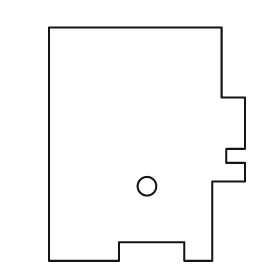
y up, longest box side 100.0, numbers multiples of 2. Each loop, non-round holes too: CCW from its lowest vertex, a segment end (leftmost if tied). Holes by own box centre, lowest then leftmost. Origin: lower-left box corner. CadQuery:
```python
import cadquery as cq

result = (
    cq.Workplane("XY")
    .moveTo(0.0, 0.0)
    .lineTo(30.0, 0.0)
    .lineTo(30.0, 8.0)
    .lineTo(58.0, 8.0)
    .lineTo(58.0, 0.0)
    .lineTo(70.0, 0.0)
    .lineTo(70.0, 34.0)
    .lineTo(84.0, 34.0)
    .lineTo(84.0, 42.0)
    .lineTo(76.0, 42.0)
    .lineTo(76.0, 48.0)
    .lineTo(84.0, 48.0)
    .lineTo(84.0, 70.0)
    .lineTo(74.0, 70.0)
    .lineTo(74.0, 100.0)
    .lineTo(0.0, 100.0)
    .close()
    .moveTo(42.0, 32.0)
    .circle(4.0)
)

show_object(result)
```